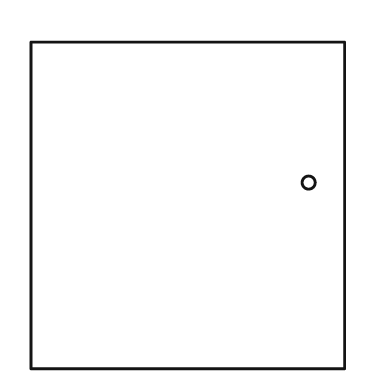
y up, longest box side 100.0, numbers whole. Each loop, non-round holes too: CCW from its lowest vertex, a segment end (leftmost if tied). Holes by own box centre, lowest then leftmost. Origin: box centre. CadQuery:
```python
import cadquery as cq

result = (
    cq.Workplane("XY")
    .moveTo(-48.0, -50.0)
    .lineTo(48.0, -50.0)
    .lineTo(48.0, 50.0)
    .lineTo(-48.0, 50.0)
    .close()
    .moveTo(37.0, 7.0)
    .circle(2.0)
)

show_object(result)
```